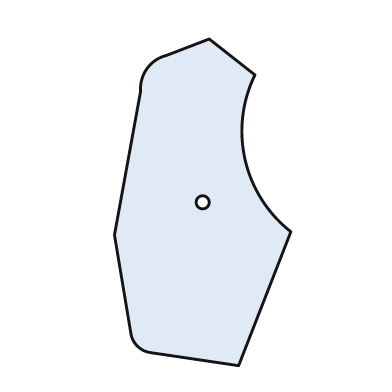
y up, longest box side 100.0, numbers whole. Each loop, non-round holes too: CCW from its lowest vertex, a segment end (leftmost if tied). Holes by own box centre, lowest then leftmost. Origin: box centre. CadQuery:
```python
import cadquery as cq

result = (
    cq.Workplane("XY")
    .moveTo(11.0, -50.0)
    .lineTo(27.0, -9.0)
    .threePointArc((13.0, 13.0), (16.0, 39.0))
    .lineTo(2.0, 50.0)
    .lineTo(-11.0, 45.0)
    .threePointArc((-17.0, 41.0), (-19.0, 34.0))
    .lineTo(-27.0, -10.0)
    .lineTo(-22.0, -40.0)
    .threePointArc((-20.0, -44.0), (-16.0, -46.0))
    .close()
    .moveTo(0.0, 0.0)
    .circle(2.0)
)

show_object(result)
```